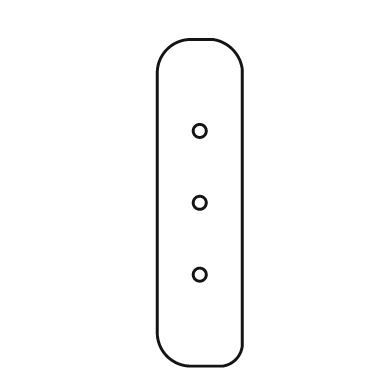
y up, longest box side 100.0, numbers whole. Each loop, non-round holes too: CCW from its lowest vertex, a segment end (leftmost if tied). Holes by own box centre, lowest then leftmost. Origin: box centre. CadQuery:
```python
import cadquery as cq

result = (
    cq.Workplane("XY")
    .moveTo(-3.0, -50.0)
    .lineTo(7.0, -50.0)
    .threePointArc((11.0, -48.0), (13.0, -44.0))
    .lineTo(13.0, 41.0)
    .threePointArc((10.0, 47.0), (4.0, 50.0))
    .lineTo(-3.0, 50.0)
    .threePointArc((-10.0, 47.0), (-13.0, 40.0))
    .lineTo(-13.0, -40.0)
    .threePointArc((-10.0, -47.0), (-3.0, -50.0))
    .close()
    .moveTo(0.0, -22.0)
    .circle(2.0)
    .moveTo(0.0, 0.0)
    .circle(2.0)
    .moveTo(0.0, 22.0)
    .circle(2.0)
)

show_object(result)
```